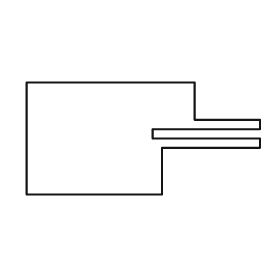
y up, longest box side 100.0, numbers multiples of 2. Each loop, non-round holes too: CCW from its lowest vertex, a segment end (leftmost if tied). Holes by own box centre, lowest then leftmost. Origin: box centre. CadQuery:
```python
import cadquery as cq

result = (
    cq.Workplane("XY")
    .moveTo(-50.0, -24.0)
    .lineTo(8.0, -24.0)
    .lineTo(8.0, -4.0)
    .lineTo(50.0, -4.0)
    .lineTo(50.0, 0.0)
    .lineTo(4.0, 0.0)
    .lineTo(4.0, 4.0)
    .lineTo(50.0, 4.0)
    .lineTo(50.0, 8.0)
    .lineTo(22.0, 8.0)
    .lineTo(22.0, 24.0)
    .lineTo(-50.0, 24.0)
    .close()
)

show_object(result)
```